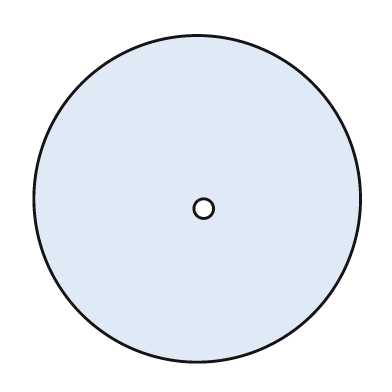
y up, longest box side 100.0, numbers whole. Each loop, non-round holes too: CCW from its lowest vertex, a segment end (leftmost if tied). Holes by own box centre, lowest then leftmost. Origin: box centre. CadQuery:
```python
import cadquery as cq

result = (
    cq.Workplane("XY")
    .moveTo(0.0, 0.0)
    .circle(50.0)
    .moveTo(2.0, -3.0)
    .circle(3.0)
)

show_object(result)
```